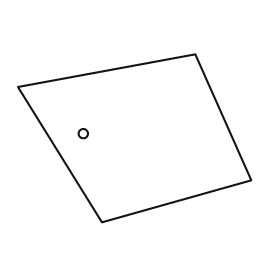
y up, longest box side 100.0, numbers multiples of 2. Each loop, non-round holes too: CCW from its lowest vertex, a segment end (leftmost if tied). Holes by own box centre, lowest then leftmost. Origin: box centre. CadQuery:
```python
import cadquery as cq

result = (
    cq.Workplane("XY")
    .moveTo(-14.0, -36.0)
    .lineTo(50.0, -18.0)
    .lineTo(26.0, 36.0)
    .lineTo(-50.0, 22.0)
    .close()
    .moveTo(-22.0, 2.0)
    .circle(2.0)
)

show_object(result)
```